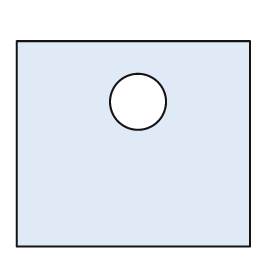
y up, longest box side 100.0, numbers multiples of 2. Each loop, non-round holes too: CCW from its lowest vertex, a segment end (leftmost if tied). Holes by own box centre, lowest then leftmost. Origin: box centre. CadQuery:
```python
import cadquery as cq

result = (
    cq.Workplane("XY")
    .moveTo(-50.0, -44.0)
    .lineTo(50.0, -44.0)
    .lineTo(50.0, 44.0)
    .lineTo(-50.0, 44.0)
    .close()
    .moveTo(2.0, 18.0)
    .circle(12.0)
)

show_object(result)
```